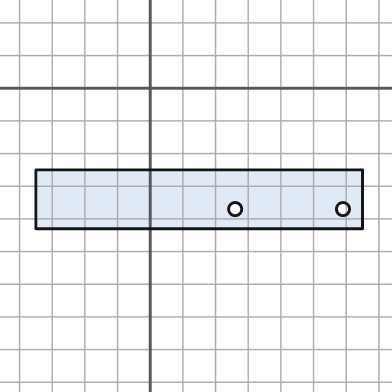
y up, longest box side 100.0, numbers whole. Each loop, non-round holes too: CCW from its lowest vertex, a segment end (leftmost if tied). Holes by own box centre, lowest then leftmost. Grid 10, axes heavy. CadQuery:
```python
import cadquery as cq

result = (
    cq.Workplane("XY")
    .moveTo(-35.0, -43.0)
    .lineTo(65.0, -43.0)
    .lineTo(65.0, -25.0)
    .lineTo(-35.0, -25.0)
    .close()
    .moveTo(26.0, -37.0)
    .circle(2.0)
    .moveTo(59.0, -37.0)
    .circle(2.0)
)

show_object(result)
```